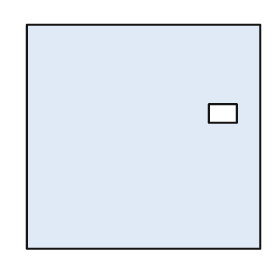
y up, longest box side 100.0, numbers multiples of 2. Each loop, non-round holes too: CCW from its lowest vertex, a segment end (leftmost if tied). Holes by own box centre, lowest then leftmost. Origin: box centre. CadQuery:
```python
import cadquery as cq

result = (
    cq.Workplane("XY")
    .moveTo(-50.0, -48.0)
    .lineTo(50.0, -48.0)
    .lineTo(50.0, 48.0)
    .lineTo(-50.0, 48.0)
    .close()
    .moveTo(28.0, 6.0)
    .lineTo(40.0, 6.0)
    .lineTo(40.0, 14.0)
    .lineTo(28.0, 14.0)
    .close()
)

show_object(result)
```